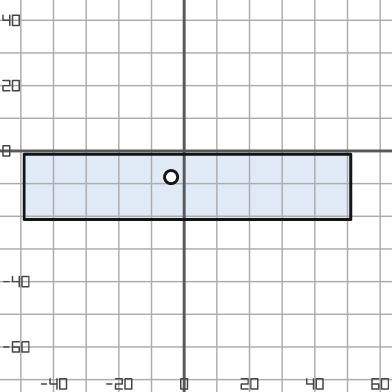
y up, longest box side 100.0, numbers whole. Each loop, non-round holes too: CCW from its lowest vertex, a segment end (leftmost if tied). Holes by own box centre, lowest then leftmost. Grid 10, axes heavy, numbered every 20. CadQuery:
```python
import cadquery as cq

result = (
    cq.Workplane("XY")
    .moveTo(-49.0, -21.0)
    .lineTo(51.0, -21.0)
    .lineTo(51.0, -1.0)
    .lineTo(-49.0, -1.0)
    .close()
    .moveTo(-4.0, -8.0)
    .circle(2.0)
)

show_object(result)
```